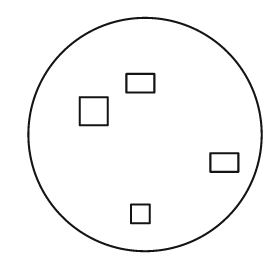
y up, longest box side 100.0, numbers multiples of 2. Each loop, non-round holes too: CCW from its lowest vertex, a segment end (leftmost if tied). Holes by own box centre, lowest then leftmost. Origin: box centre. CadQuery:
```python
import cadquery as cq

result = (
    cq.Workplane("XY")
    .moveTo(0.0, 0.0)
    .circle(50.0)
    .moveTo(-6.0, -38.0)
    .lineTo(2.0, -38.0)
    .lineTo(2.0, -30.0)
    .lineTo(-6.0, -30.0)
    .close()
    .moveTo(28.0, -16.0)
    .lineTo(40.0, -16.0)
    .lineTo(40.0, -8.0)
    .lineTo(28.0, -8.0)
    .close()
    .moveTo(-28.0, 4.0)
    .lineTo(-16.0, 4.0)
    .lineTo(-16.0, 16.0)
    .lineTo(-28.0, 16.0)
    .close()
    .moveTo(-8.0, 18.0)
    .lineTo(4.0, 18.0)
    .lineTo(4.0, 26.0)
    .lineTo(-8.0, 26.0)
    .close()
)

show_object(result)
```